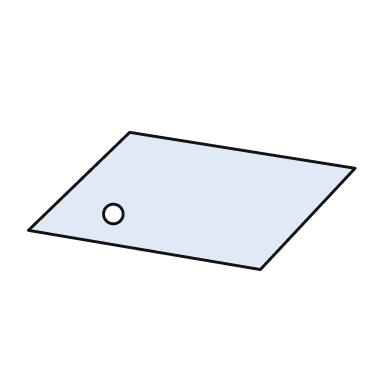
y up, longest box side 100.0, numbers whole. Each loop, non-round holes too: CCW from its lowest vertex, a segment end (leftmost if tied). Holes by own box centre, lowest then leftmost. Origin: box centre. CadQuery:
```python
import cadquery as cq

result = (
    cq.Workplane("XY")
    .moveTo(21.0, -21.0)
    .lineTo(50.0, 10.0)
    .lineTo(-19.0, 21.0)
    .lineTo(-50.0, -9.0)
    .close()
    .moveTo(-24.0, -4.0)
    .circle(3.0)
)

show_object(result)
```